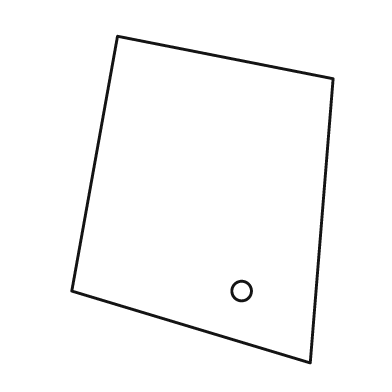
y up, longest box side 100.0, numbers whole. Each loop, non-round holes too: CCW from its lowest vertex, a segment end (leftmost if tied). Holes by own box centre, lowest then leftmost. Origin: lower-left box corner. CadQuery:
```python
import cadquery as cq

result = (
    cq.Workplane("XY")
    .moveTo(73.0, 0.0)
    .lineTo(80.0, 87.0)
    .lineTo(14.0, 100.0)
    .lineTo(0.0, 22.0)
    .close()
    .moveTo(52.0, 22.0)
    .circle(3.0)
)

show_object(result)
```